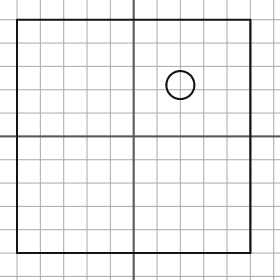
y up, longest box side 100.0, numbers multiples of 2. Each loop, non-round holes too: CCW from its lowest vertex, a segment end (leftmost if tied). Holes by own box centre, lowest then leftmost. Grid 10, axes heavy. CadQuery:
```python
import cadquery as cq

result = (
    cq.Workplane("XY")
    .moveTo(-50.0, -50.0)
    .lineTo(50.0, -50.0)
    .lineTo(50.0, 50.0)
    .lineTo(-50.0, 50.0)
    .close()
    .moveTo(20.0, 22.0)
    .circle(6.0)
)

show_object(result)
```